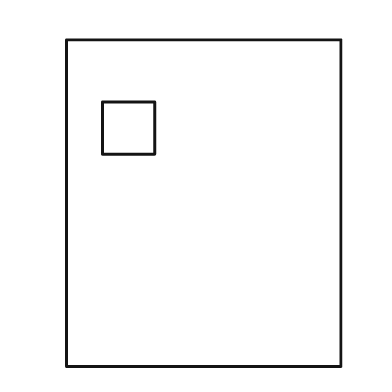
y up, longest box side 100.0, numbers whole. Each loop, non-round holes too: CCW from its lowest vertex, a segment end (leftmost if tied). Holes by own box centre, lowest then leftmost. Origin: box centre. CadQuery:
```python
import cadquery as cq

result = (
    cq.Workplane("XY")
    .moveTo(-42.0, -50.0)
    .lineTo(42.0, -50.0)
    .lineTo(42.0, 50.0)
    .lineTo(-42.0, 50.0)
    .close()
    .moveTo(-31.0, 15.0)
    .lineTo(-15.0, 15.0)
    .lineTo(-15.0, 31.0)
    .lineTo(-31.0, 31.0)
    .close()
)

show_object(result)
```